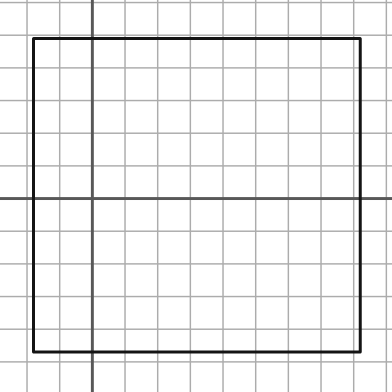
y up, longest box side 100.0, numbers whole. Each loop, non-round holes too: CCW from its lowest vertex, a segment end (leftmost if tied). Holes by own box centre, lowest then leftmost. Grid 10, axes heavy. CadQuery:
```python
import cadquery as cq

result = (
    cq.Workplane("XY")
    .moveTo(-18.0, -47.0)
    .lineTo(82.0, -47.0)
    .lineTo(82.0, 49.0)
    .lineTo(-18.0, 49.0)
    .close()
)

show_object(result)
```